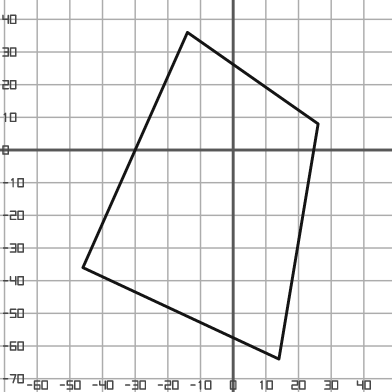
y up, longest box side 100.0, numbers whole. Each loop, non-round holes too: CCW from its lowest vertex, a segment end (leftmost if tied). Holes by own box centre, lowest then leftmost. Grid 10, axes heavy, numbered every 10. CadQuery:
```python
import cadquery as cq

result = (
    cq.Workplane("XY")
    .moveTo(14.0, -64.0)
    .lineTo(26.0, 8.0)
    .lineTo(-14.0, 36.0)
    .lineTo(-46.0, -36.0)
    .close()
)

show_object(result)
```